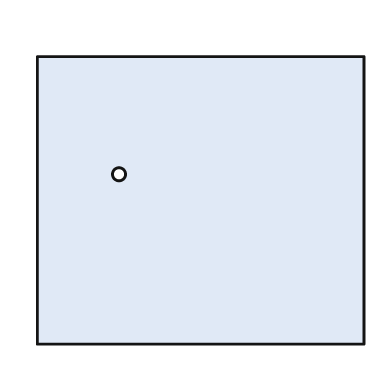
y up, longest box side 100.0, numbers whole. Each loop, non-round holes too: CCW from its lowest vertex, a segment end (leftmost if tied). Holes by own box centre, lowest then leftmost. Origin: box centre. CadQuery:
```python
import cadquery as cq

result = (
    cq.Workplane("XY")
    .moveTo(-50.0, -44.0)
    .lineTo(50.0, -44.0)
    .lineTo(50.0, 44.0)
    .lineTo(-50.0, 44.0)
    .close()
    .moveTo(-25.0, 8.0)
    .circle(2.0)
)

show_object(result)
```